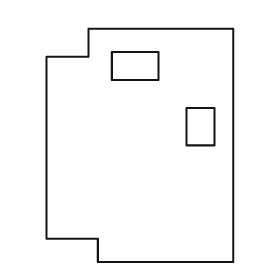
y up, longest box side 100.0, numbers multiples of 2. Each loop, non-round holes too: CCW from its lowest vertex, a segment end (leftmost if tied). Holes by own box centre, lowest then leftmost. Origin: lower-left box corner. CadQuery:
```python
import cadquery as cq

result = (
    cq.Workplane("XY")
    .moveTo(22.0, 0.0)
    .lineTo(80.0, 0.0)
    .lineTo(80.0, 100.0)
    .lineTo(18.0, 100.0)
    .lineTo(18.0, 88.0)
    .lineTo(0.0, 88.0)
    .lineTo(0.0, 10.0)
    .lineTo(22.0, 10.0)
    .close()
    .moveTo(60.0, 50.0)
    .lineTo(72.0, 50.0)
    .lineTo(72.0, 66.0)
    .lineTo(60.0, 66.0)
    .close()
    .moveTo(28.0, 78.0)
    .lineTo(48.0, 78.0)
    .lineTo(48.0, 90.0)
    .lineTo(28.0, 90.0)
    .close()
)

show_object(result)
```